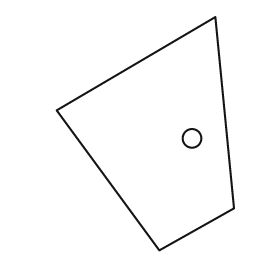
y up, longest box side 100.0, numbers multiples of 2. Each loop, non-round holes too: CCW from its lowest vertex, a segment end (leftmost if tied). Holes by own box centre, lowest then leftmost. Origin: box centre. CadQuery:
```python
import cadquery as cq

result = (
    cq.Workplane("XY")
    .moveTo(6.0, -50.0)
    .lineTo(38.0, -32.0)
    .lineTo(30.0, 50.0)
    .lineTo(-38.0, 10.0)
    .close()
    .moveTo(20.0, -2.0)
    .circle(4.0)
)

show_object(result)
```